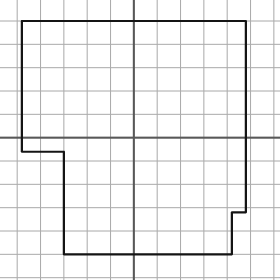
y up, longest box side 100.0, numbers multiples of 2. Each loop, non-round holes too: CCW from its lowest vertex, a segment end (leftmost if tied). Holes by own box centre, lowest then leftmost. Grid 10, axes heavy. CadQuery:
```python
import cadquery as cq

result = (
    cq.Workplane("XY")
    .moveTo(-30.0, -50.0)
    .lineTo(42.0, -50.0)
    .lineTo(42.0, -32.0)
    .lineTo(48.0, -32.0)
    .lineTo(48.0, 50.0)
    .lineTo(-48.0, 50.0)
    .lineTo(-48.0, -6.0)
    .lineTo(-30.0, -6.0)
    .close()
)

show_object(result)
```